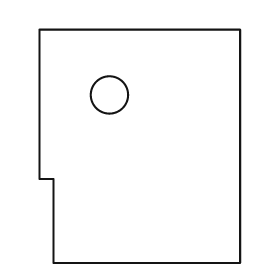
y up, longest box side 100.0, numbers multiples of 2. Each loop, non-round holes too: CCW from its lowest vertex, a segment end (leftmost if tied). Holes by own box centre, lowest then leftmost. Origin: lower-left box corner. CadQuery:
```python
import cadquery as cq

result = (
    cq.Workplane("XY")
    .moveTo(6.0, 0.0)
    .lineTo(86.0, 0.0)
    .lineTo(86.0, 100.0)
    .lineTo(0.0, 100.0)
    .lineTo(0.0, 36.0)
    .lineTo(6.0, 36.0)
    .close()
    .moveTo(30.0, 72.0)
    .circle(8.0)
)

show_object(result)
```